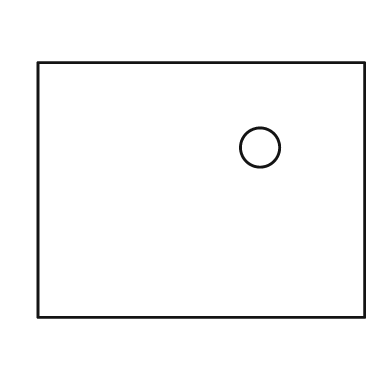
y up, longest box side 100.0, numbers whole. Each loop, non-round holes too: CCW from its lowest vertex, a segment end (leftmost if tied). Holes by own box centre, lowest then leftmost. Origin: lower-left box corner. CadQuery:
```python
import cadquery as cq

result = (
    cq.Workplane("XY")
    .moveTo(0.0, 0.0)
    .lineTo(100.0, 0.0)
    .lineTo(100.0, 78.0)
    .lineTo(0.0, 78.0)
    .close()
    .moveTo(68.0, 52.0)
    .circle(6.0)
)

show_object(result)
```